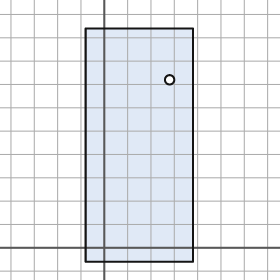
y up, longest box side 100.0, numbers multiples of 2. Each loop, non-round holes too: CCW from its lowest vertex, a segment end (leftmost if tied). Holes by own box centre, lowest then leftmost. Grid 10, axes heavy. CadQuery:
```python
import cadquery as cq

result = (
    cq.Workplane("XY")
    .moveTo(-8.0, -6.0)
    .lineTo(38.0, -6.0)
    .lineTo(38.0, 94.0)
    .lineTo(-8.0, 94.0)
    .close()
    .moveTo(28.0, 72.0)
    .circle(2.0)
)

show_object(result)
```